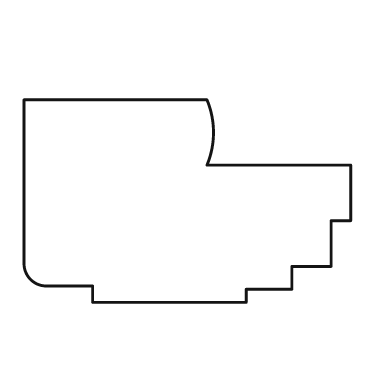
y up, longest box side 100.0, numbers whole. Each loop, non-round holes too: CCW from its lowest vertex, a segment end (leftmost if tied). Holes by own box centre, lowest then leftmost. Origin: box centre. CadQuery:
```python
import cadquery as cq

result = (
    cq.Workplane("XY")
    .moveTo(-29.0, -31.0)
    .lineTo(18.0, -31.0)
    .lineTo(18.0, -27.0)
    .lineTo(32.0, -27.0)
    .lineTo(32.0, -20.0)
    .lineTo(44.0, -20.0)
    .lineTo(44.0, -6.0)
    .lineTo(50.0, -6.0)
    .lineTo(50.0, 11.0)
    .lineTo(6.0, 11.0)
    .threePointArc((8.0, 21.0), (6.0, 31.0))
    .lineTo(-50.0, 31.0)
    .lineTo(-50.0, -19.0)
    .threePointArc((-48.0, -24.0), (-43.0, -26.0))
    .lineTo(-29.0, -26.0)
    .close()
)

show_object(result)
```